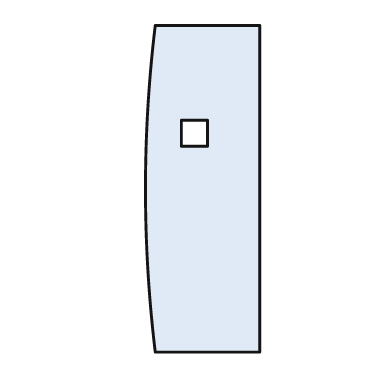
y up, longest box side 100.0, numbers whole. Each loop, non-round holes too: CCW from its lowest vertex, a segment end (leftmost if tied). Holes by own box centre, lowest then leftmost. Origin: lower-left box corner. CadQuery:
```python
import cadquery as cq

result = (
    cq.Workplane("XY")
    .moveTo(3.0, 0.0)
    .lineTo(35.0, 0.0)
    .lineTo(35.0, 100.0)
    .lineTo(3.0, 100.0)
    .threePointArc((0.0, 50.0), (3.0, 0.0))
    .close()
    .moveTo(11.0, 63.0)
    .lineTo(19.0, 63.0)
    .lineTo(19.0, 71.0)
    .lineTo(11.0, 71.0)
    .close()
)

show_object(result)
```